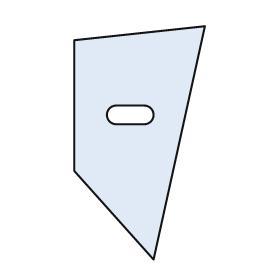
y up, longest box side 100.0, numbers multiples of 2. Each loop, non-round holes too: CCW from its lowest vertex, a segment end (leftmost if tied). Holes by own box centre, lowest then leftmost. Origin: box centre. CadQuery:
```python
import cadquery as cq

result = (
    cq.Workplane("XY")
    .moveTo(6.0, -50.0)
    .lineTo(28.0, 50.0)
    .lineTo(-28.0, 44.0)
    .lineTo(-28.0, -12.0)
    .close()
    .moveTo(-10.0, 8.0)
    .lineTo(2.0, 8.0)
    .threePointArc((6.0, 12.0), (2.0, 16.0))
    .lineTo(-10.0, 16.0)
    .threePointArc((-14.0, 12.0), (-10.0, 8.0))
    .close()
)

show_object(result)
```